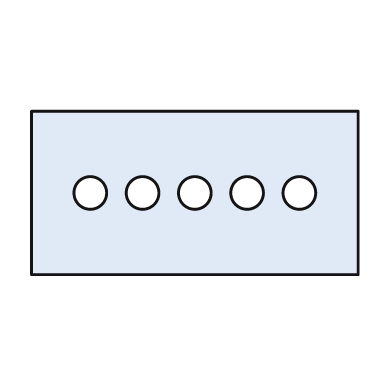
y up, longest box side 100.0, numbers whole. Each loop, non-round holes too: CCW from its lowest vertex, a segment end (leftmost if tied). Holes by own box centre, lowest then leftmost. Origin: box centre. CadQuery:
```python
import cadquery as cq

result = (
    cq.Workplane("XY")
    .moveTo(-50.0, -25.0)
    .lineTo(50.0, -25.0)
    .lineTo(50.0, 25.0)
    .lineTo(-50.0, 25.0)
    .close()
    .moveTo(-32.0, 0.0)
    .circle(5.0)
    .moveTo(-16.0, 0.0)
    .circle(5.0)
    .moveTo(0.0, 0.0)
    .circle(5.0)
    .moveTo(16.0, 0.0)
    .circle(5.0)
    .moveTo(32.0, 0.0)
    .circle(5.0)
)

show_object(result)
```